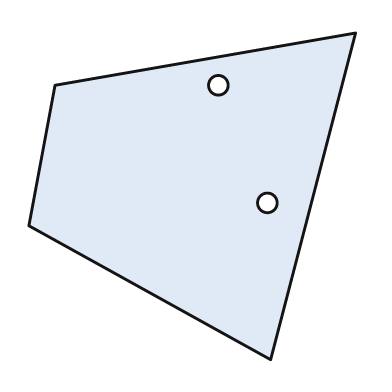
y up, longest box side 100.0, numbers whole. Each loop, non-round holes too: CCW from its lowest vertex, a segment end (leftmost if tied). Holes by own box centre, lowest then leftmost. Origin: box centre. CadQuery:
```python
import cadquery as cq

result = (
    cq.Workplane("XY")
    .moveTo(24.0, -50.0)
    .lineTo(50.0, 50.0)
    .lineTo(-42.0, 34.0)
    .lineTo(-50.0, -9.0)
    .close()
    .moveTo(23.0, -2.0)
    .circle(3.0)
    .moveTo(8.0, 34.0)
    .circle(3.0)
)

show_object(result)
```